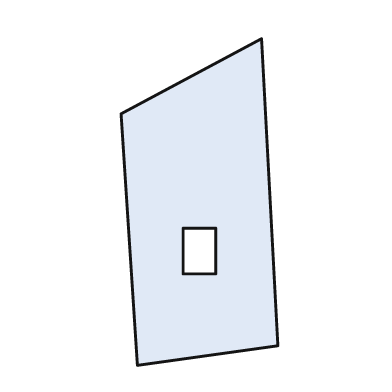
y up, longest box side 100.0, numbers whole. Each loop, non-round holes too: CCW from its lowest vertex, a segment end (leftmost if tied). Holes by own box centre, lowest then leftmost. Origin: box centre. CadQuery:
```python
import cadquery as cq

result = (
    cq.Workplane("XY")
    .moveTo(-19.0, -50.0)
    .lineTo(24.0, -44.0)
    .lineTo(19.0, 50.0)
    .lineTo(-24.0, 27.0)
    .close()
    .moveTo(-5.0, -22.0)
    .lineTo(5.0, -22.0)
    .lineTo(5.0, -8.0)
    .lineTo(-5.0, -8.0)
    .close()
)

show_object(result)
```